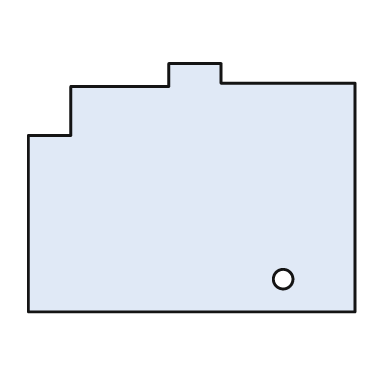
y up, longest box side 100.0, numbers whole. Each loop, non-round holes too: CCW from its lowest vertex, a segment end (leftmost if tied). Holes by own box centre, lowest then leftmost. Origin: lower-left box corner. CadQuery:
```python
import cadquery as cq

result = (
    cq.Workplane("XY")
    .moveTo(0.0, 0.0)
    .lineTo(100.0, 0.0)
    .lineTo(100.0, 70.0)
    .lineTo(59.0, 70.0)
    .lineTo(59.0, 76.0)
    .lineTo(43.0, 76.0)
    .lineTo(43.0, 69.0)
    .lineTo(13.0, 69.0)
    .lineTo(13.0, 54.0)
    .lineTo(0.0, 54.0)
    .close()
    .moveTo(78.0, 10.0)
    .circle(3.0)
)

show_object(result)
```